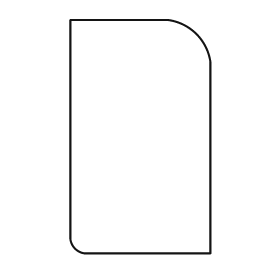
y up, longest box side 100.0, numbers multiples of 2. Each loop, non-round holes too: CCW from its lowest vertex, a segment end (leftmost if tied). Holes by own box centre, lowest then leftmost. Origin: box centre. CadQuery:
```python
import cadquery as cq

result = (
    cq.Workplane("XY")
    .moveTo(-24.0, -50.0)
    .lineTo(30.0, -50.0)
    .lineTo(30.0, 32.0)
    .threePointArc((24.0, 44.0), (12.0, 50.0))
    .lineTo(-30.0, 50.0)
    .lineTo(-30.0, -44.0)
    .threePointArc((-28.0, -48.0), (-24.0, -50.0))
    .close()
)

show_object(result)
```